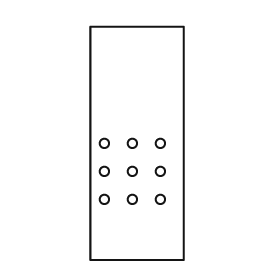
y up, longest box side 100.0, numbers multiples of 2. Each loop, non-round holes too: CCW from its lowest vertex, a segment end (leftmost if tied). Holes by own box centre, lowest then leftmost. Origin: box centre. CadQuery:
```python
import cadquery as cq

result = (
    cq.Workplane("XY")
    .moveTo(-20.0, -50.0)
    .lineTo(20.0, -50.0)
    .lineTo(20.0, 50.0)
    .lineTo(-20.0, 50.0)
    .close()
    .moveTo(-14.0, -24.0)
    .circle(2.0)
    .moveTo(-2.0, -24.0)
    .circle(2.0)
    .moveTo(10.0, -24.0)
    .circle(2.0)
    .moveTo(-14.0, -12.0)
    .circle(2.0)
    .moveTo(-2.0, -12.0)
    .circle(2.0)
    .moveTo(10.0, -12.0)
    .circle(2.0)
    .moveTo(-14.0, 0.0)
    .circle(2.0)
    .moveTo(-2.0, 0.0)
    .circle(2.0)
    .moveTo(10.0, 0.0)
    .circle(2.0)
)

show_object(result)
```